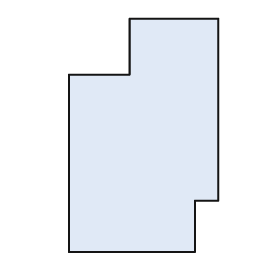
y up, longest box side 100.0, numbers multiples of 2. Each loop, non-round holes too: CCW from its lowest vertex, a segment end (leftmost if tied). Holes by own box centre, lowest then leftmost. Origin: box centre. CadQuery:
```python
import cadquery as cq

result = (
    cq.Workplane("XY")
    .moveTo(-32.0, -50.0)
    .lineTo(22.0, -50.0)
    .lineTo(22.0, -28.0)
    .lineTo(32.0, -28.0)
    .lineTo(32.0, 50.0)
    .lineTo(-6.0, 50.0)
    .lineTo(-6.0, 26.0)
    .lineTo(-32.0, 26.0)
    .close()
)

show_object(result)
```